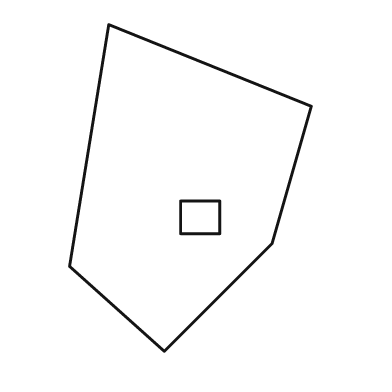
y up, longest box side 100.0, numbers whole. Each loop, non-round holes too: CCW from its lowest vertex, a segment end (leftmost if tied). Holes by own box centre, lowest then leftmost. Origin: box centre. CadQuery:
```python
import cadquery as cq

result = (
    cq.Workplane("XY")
    .moveTo(-8.0, -50.0)
    .lineTo(25.0, -17.0)
    .lineTo(37.0, 25.0)
    .lineTo(-25.0, 50.0)
    .lineTo(-37.0, -24.0)
    .close()
    .moveTo(-3.0, -14.0)
    .lineTo(9.0, -14.0)
    .lineTo(9.0, -4.0)
    .lineTo(-3.0, -4.0)
    .close()
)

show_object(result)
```